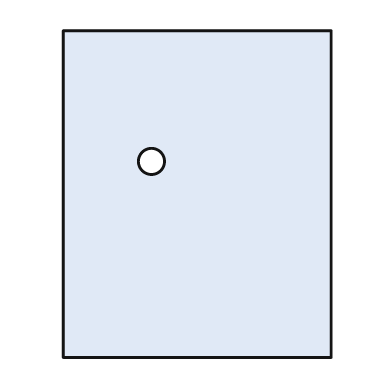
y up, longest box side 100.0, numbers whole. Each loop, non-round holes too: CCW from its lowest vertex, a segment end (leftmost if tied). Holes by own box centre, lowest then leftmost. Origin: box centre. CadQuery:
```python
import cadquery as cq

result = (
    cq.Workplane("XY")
    .moveTo(-41.0, -50.0)
    .lineTo(41.0, -50.0)
    .lineTo(41.0, 50.0)
    .lineTo(-41.0, 50.0)
    .close()
    .moveTo(-14.0, 10.0)
    .circle(4.0)
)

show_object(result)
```